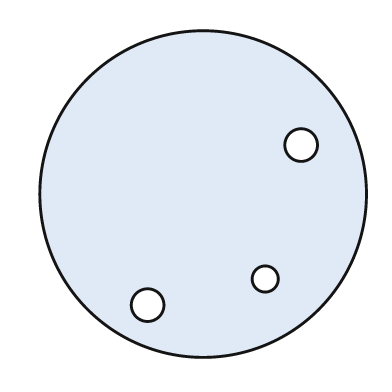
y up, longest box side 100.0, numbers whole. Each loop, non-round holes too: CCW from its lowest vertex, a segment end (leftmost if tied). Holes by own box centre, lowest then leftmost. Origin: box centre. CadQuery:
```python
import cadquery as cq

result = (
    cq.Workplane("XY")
    .moveTo(0.0, 0.0)
    .circle(50.0)
    .moveTo(-17.0, -34.0)
    .circle(5.0)
    .moveTo(19.0, -26.0)
    .circle(4.0)
    .moveTo(30.0, 15.0)
    .circle(5.0)
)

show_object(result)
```